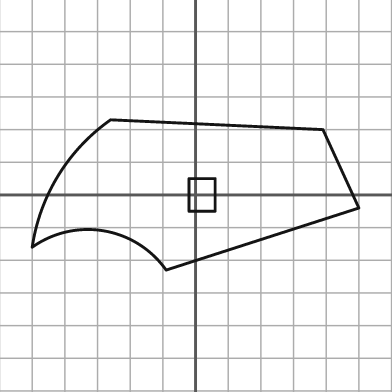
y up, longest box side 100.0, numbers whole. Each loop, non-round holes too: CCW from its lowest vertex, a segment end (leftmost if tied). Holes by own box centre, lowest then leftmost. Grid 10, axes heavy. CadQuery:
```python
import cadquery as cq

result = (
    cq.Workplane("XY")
    .moveTo(-9.0, -23.0)
    .lineTo(50.0, -4.0)
    .lineTo(39.0, 20.0)
    .lineTo(-26.0, 23.0)
    .threePointArc((-42.0, 6.0), (-50.0, -16.0))
    .threePointArc((-28.0, -11.0), (-9.0, -23.0))
    .close()
    .moveTo(-2.0, -5.0)
    .lineTo(6.0, -5.0)
    .lineTo(6.0, 5.0)
    .lineTo(-2.0, 5.0)
    .close()
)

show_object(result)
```